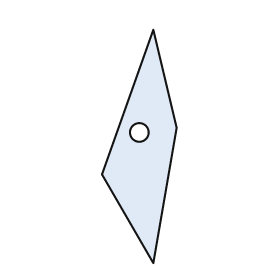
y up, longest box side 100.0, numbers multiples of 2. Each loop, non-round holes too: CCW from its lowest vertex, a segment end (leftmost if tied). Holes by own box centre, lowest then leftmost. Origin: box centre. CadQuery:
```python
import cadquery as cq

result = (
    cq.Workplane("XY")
    .moveTo(6.0, -50.0)
    .lineTo(16.0, 8.0)
    .lineTo(6.0, 50.0)
    .lineTo(-16.0, -12.0)
    .close()
    .moveTo(0.0, 6.0)
    .circle(4.0)
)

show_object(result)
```